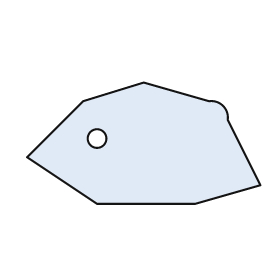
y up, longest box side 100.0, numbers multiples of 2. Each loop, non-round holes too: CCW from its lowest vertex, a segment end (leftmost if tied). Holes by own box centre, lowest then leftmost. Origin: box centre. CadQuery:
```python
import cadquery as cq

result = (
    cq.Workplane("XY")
    .moveTo(-20.0, -26.0)
    .lineTo(22.0, -26.0)
    .lineTo(50.0, -18.0)
    .lineTo(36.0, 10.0)
    .threePointArc((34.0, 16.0), (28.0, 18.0))
    .lineTo(0.0, 26.0)
    .lineTo(-26.0, 18.0)
    .lineTo(-50.0, -6.0)
    .close()
    .moveTo(-20.0, 2.0)
    .circle(4.0)
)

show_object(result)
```